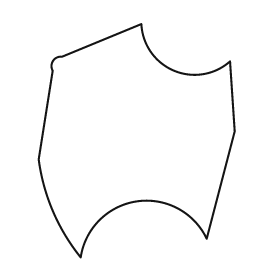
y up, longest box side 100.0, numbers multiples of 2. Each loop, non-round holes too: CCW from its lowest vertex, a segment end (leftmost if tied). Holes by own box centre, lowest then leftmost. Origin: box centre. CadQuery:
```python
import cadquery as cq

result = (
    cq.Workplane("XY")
    .moveTo(-24.0, -50.0)
    .threePointArc((0.0, -26.0), (30.0, -42.0))
    .lineTo(42.0, 4.0)
    .lineTo(40.0, 34.0)
    .threePointArc((16.0, 30.0), (2.0, 50.0))
    .lineTo(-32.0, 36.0)
    .threePointArc((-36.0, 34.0), (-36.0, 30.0))
    .lineTo(-42.0, -8.0)
    .threePointArc((-36.0, -30.0), (-24.0, -50.0))
    .close()
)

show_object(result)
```